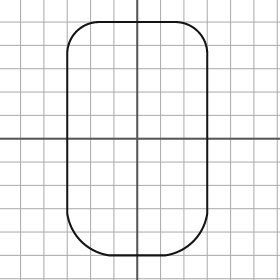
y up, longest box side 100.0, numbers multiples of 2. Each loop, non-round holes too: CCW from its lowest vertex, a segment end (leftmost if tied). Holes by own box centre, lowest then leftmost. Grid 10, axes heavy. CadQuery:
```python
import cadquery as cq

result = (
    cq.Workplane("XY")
    .moveTo(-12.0, -50.0)
    .lineTo(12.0, -50.0)
    .threePointArc((24.0, -44.0), (30.0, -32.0))
    .lineTo(30.0, 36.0)
    .threePointArc((26.0, 46.0), (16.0, 50.0))
    .lineTo(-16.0, 50.0)
    .threePointArc((-26.0, 46.0), (-30.0, 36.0))
    .lineTo(-30.0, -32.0)
    .threePointArc((-24.0, -44.0), (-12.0, -50.0))
    .close()
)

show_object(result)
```